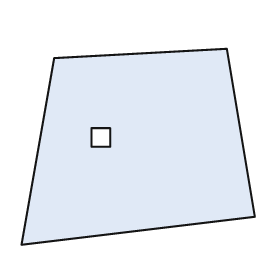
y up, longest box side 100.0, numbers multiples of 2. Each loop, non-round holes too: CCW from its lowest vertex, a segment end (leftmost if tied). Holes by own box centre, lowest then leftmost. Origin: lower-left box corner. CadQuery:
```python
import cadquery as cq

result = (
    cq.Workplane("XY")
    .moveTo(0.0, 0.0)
    .lineTo(100.0, 12.0)
    .lineTo(88.0, 84.0)
    .lineTo(14.0, 80.0)
    .close()
    .moveTo(30.0, 42.0)
    .lineTo(38.0, 42.0)
    .lineTo(38.0, 50.0)
    .lineTo(30.0, 50.0)
    .close()
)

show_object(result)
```